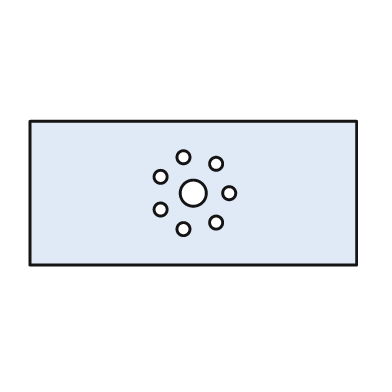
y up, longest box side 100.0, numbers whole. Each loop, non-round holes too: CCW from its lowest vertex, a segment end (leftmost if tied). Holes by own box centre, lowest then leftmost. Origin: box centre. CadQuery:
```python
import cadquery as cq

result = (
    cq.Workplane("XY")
    .moveTo(-50.0, -22.0)
    .lineTo(50.0, -22.0)
    .lineTo(50.0, 22.0)
    .lineTo(-50.0, 22.0)
    .close()
    .moveTo(-3.0, -11.0)
    .circle(2.0)
    .moveTo(7.0, -9.0)
    .circle(2.0)
    .moveTo(-10.0, -5.0)
    .circle(2.0)
    .moveTo(0.0, 0.0)
    .circle(4.0)
    .moveTo(11.0, 0.0)
    .circle(2.0)
    .moveTo(-10.0, 5.0)
    .circle(2.0)
    .moveTo(7.0, 9.0)
    .circle(2.0)
    .moveTo(-3.0, 11.0)
    .circle(2.0)
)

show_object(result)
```